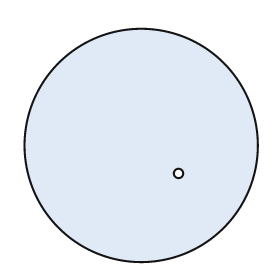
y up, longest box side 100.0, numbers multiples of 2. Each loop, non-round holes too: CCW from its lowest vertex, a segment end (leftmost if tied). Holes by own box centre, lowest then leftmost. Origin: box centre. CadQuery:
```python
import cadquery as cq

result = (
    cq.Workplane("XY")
    .moveTo(0.0, 0.0)
    .circle(50.0)
    .moveTo(16.0, -12.0)
    .circle(2.0)
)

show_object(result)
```